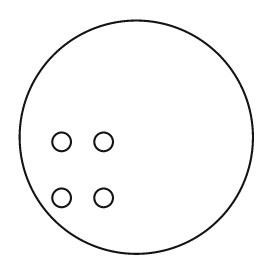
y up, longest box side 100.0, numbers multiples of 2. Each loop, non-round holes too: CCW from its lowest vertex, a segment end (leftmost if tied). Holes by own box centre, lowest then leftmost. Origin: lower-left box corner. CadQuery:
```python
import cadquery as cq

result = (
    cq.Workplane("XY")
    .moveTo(50.0, 50.0)
    .circle(50.0)
    .moveTo(18.0, 24.0)
    .circle(4.0)
    .moveTo(36.0, 24.0)
    .circle(4.0)
    .moveTo(18.0, 48.0)
    .circle(4.0)
    .moveTo(36.0, 48.0)
    .circle(4.0)
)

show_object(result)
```